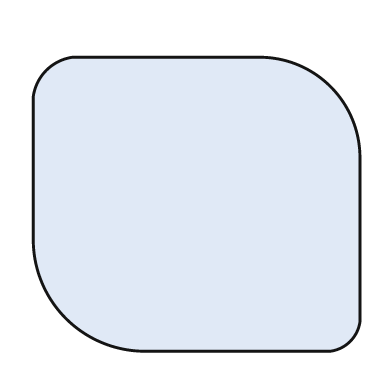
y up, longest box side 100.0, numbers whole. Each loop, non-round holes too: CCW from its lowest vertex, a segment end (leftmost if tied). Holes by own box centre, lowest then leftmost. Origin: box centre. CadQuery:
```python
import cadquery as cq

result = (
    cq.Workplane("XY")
    .moveTo(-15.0, -45.0)
    .lineTo(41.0, -45.0)
    .threePointArc((47.0, -42.0), (50.0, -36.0))
    .lineTo(50.0, 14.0)
    .threePointArc((41.0, 36.0), (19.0, 45.0))
    .lineTo(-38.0, 45.0)
    .threePointArc((-46.0, 41.0), (-50.0, 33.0))
    .lineTo(-50.0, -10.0)
    .threePointArc((-40.0, -35.0), (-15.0, -45.0))
    .close()
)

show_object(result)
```